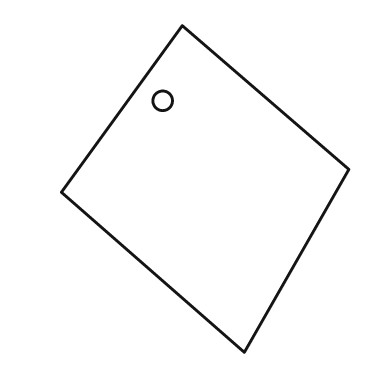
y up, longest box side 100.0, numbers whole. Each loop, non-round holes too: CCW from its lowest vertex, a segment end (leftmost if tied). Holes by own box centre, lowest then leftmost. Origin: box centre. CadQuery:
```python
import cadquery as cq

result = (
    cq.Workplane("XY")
    .moveTo(12.0, -50.0)
    .lineTo(44.0, 6.0)
    .lineTo(-7.0, 50.0)
    .lineTo(-44.0, -1.0)
    .close()
    .moveTo(-13.0, 27.0)
    .circle(3.0)
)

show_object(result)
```